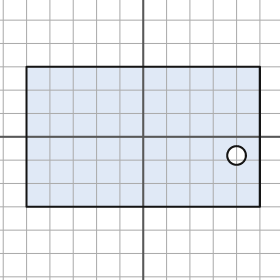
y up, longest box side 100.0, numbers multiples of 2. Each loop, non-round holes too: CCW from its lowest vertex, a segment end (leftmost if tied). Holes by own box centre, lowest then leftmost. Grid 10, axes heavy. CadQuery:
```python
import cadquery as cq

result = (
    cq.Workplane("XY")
    .moveTo(-50.0, -30.0)
    .lineTo(50.0, -30.0)
    .lineTo(50.0, 30.0)
    .lineTo(-50.0, 30.0)
    .close()
    .moveTo(40.0, -8.0)
    .circle(4.0)
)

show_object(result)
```